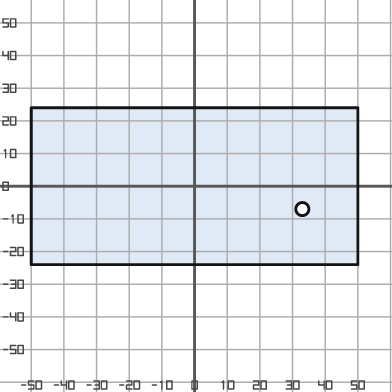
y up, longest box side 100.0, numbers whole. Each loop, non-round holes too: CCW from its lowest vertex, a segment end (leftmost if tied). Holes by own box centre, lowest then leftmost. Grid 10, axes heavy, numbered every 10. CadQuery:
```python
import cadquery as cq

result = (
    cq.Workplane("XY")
    .moveTo(-50.0, -24.0)
    .lineTo(50.0, -24.0)
    .lineTo(50.0, 24.0)
    .lineTo(-50.0, 24.0)
    .close()
    .moveTo(33.0, -7.0)
    .circle(2.0)
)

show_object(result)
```